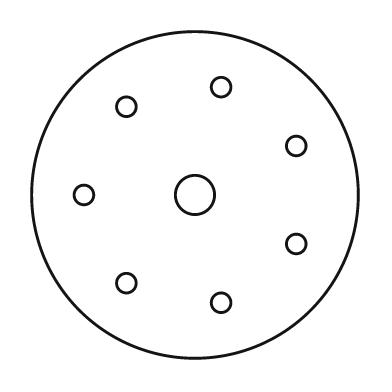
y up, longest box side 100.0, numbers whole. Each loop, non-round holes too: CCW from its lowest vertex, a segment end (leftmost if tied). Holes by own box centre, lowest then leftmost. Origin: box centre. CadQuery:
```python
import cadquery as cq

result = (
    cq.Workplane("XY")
    .moveTo(0.0, 0.0)
    .circle(50.0)
    .moveTo(8.0, -33.0)
    .circle(3.0)
    .moveTo(-21.0, -27.0)
    .circle(3.0)
    .moveTo(31.0, -15.0)
    .circle(3.0)
    .moveTo(-34.0, 0.0)
    .circle(3.0)
    .moveTo(0.0, 0.0)
    .circle(6.0)
    .moveTo(31.0, 15.0)
    .circle(3.0)
    .moveTo(-21.0, 27.0)
    .circle(3.0)
    .moveTo(8.0, 33.0)
    .circle(3.0)
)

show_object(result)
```